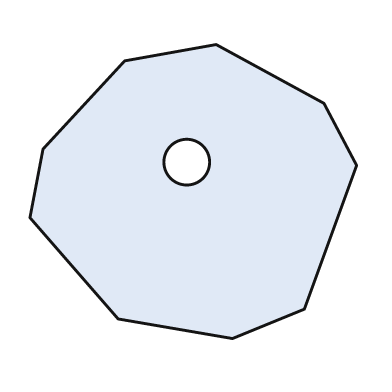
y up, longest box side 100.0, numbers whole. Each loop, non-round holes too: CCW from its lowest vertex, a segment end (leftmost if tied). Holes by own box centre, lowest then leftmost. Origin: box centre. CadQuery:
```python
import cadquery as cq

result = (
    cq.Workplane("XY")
    .moveTo(12.0, -45.0)
    .lineTo(34.0, -36.0)
    .lineTo(50.0, 8.0)
    .lineTo(40.0, 27.0)
    .lineTo(7.0, 45.0)
    .lineTo(-21.0, 40.0)
    .lineTo(-46.0, 13.0)
    .lineTo(-50.0, -8.0)
    .lineTo(-23.0, -39.0)
    .close()
    .moveTo(-2.0, 9.0)
    .circle(7.0)
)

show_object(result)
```